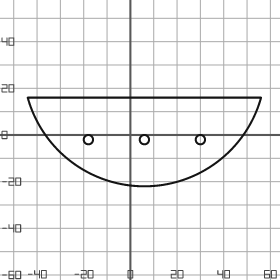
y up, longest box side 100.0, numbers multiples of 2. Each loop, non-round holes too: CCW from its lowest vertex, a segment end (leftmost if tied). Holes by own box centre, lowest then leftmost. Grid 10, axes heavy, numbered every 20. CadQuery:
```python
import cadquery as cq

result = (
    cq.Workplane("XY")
    .moveTo(-44.0, 16.0)
    .threePointArc((6.0, -22.0), (56.0, 16.0))
    .close()
    .moveTo(-18.0, -2.0)
    .circle(2.0)
    .moveTo(6.0, -2.0)
    .circle(2.0)
    .moveTo(30.0, -2.0)
    .circle(2.0)
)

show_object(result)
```